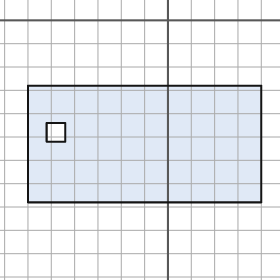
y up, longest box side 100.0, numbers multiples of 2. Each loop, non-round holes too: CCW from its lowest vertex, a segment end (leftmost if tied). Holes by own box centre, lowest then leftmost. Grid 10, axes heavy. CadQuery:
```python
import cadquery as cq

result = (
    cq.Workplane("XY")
    .moveTo(-60.0, -78.0)
    .lineTo(40.0, -78.0)
    .lineTo(40.0, -28.0)
    .lineTo(-60.0, -28.0)
    .close()
    .moveTo(-52.0, -52.0)
    .lineTo(-44.0, -52.0)
    .lineTo(-44.0, -44.0)
    .lineTo(-52.0, -44.0)
    .close()
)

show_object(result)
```